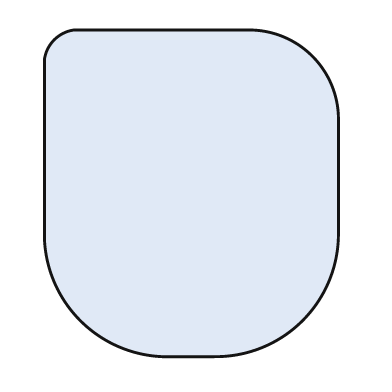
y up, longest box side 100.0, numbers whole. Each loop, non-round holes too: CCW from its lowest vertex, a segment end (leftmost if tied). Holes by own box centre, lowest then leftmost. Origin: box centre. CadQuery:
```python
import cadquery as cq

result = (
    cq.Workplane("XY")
    .moveTo(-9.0, -50.0)
    .lineTo(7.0, -50.0)
    .threePointArc((34.0, -39.0), (45.0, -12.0))
    .lineTo(45.0, 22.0)
    .threePointArc((37.0, 42.0), (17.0, 50.0))
    .lineTo(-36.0, 50.0)
    .threePointArc((-42.0, 47.0), (-45.0, 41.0))
    .lineTo(-45.0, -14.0)
    .threePointArc((-34.0, -39.0), (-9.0, -50.0))
    .close()
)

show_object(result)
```